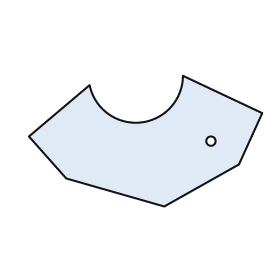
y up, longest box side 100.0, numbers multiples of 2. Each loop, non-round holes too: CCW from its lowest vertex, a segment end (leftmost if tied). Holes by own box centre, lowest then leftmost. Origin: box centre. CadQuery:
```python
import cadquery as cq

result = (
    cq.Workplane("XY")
    .moveTo(8.0, -28.0)
    .lineTo(40.0, -10.0)
    .lineTo(50.0, 12.0)
    .lineTo(16.0, 28.0)
    .threePointArc((-2.0, 8.0), (-24.0, 24.0))
    .lineTo(-50.0, 2.0)
    .lineTo(-34.0, -16.0)
    .close()
    .moveTo(28.0, 0.0)
    .circle(2.0)
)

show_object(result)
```